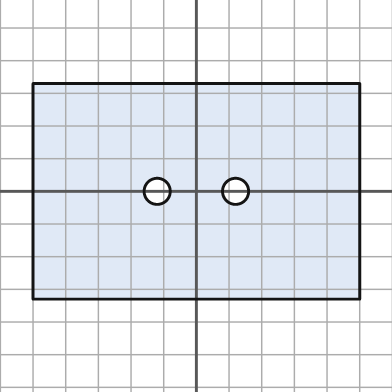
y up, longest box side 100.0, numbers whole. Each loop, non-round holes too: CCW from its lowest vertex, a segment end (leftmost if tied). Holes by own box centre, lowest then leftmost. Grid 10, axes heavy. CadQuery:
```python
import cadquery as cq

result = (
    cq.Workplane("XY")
    .moveTo(-50.0, -33.0)
    .lineTo(50.0, -33.0)
    .lineTo(50.0, 33.0)
    .lineTo(-50.0, 33.0)
    .close()
    .moveTo(-12.0, 0.0)
    .circle(4.0)
    .moveTo(12.0, 0.0)
    .circle(4.0)
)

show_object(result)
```